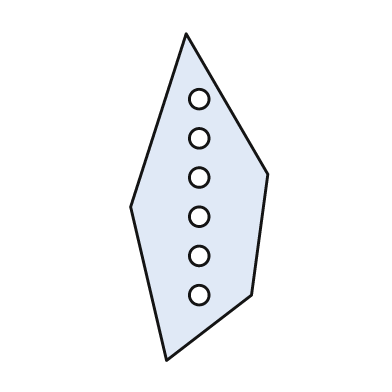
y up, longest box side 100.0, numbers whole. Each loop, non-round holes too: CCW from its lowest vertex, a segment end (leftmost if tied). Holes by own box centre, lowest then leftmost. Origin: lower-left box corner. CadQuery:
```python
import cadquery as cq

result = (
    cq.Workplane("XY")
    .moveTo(11.0, 0.0)
    .lineTo(37.0, 20.0)
    .lineTo(42.0, 57.0)
    .lineTo(17.0, 100.0)
    .lineTo(0.0, 47.0)
    .close()
    .moveTo(21.0, 20.0)
    .circle(3.0)
    .moveTo(21.0, 32.0)
    .circle(3.0)
    .moveTo(21.0, 44.0)
    .circle(3.0)
    .moveTo(21.0, 56.0)
    .circle(3.0)
    .moveTo(21.0, 68.0)
    .circle(3.0)
    .moveTo(21.0, 80.0)
    .circle(3.0)
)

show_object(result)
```